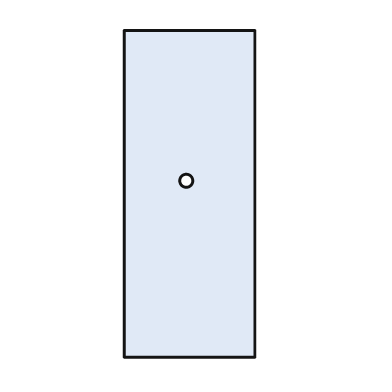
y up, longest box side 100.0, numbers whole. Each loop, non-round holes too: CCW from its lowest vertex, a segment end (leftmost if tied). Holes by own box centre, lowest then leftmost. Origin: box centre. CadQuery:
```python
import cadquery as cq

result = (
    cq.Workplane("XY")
    .moveTo(-20.0, -50.0)
    .lineTo(20.0, -50.0)
    .lineTo(20.0, 50.0)
    .lineTo(-20.0, 50.0)
    .close()
    .moveTo(-1.0, 4.0)
    .circle(2.0)
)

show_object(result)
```